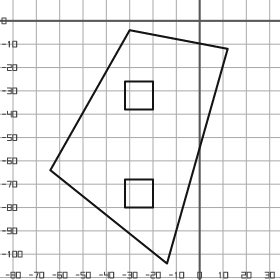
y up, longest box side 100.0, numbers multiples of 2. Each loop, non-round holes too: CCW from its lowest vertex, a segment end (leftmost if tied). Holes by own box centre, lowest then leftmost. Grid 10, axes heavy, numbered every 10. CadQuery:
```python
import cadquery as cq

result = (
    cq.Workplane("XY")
    .moveTo(-14.0, -104.0)
    .lineTo(12.0, -12.0)
    .lineTo(-30.0, -4.0)
    .lineTo(-64.0, -64.0)
    .close()
    .moveTo(-32.0, -80.0)
    .lineTo(-20.0, -80.0)
    .lineTo(-20.0, -68.0)
    .lineTo(-32.0, -68.0)
    .close()
    .moveTo(-32.0, -38.0)
    .lineTo(-20.0, -38.0)
    .lineTo(-20.0, -26.0)
    .lineTo(-32.0, -26.0)
    .close()
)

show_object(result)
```